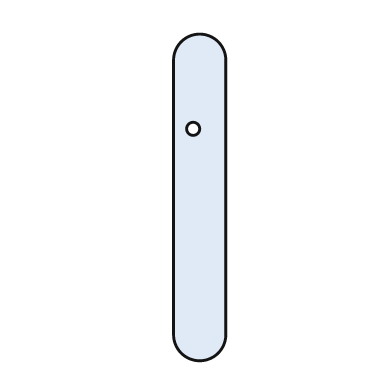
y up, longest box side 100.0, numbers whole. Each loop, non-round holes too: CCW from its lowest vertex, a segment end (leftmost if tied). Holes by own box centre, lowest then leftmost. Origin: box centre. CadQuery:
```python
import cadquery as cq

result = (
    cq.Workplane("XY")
    .moveTo(-8.0, -42.0)
    .threePointArc((0.0, -50.0), (8.0, -42.0))
    .lineTo(8.0, 42.0)
    .threePointArc((0.0, 50.0), (-8.0, 42.0))
    .close()
    .moveTo(-2.0, 21.0)
    .circle(2.0)
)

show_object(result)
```